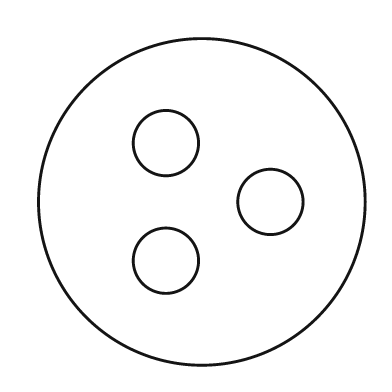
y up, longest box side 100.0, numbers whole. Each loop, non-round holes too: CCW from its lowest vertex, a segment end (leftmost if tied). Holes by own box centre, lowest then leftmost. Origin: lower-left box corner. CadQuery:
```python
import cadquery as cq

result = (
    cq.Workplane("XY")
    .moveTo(50.0, 50.0)
    .circle(50.0)
    .moveTo(39.0, 32.0)
    .circle(10.0)
    .moveTo(71.0, 50.0)
    .circle(10.0)
    .moveTo(39.0, 68.0)
    .circle(10.0)
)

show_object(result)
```